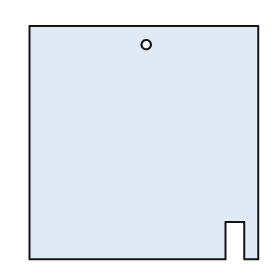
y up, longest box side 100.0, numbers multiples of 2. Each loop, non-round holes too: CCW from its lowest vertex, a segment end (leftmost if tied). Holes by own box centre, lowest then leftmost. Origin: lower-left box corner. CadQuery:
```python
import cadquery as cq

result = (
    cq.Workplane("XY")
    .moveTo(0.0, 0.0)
    .lineTo(84.0, 0.0)
    .lineTo(84.0, 16.0)
    .lineTo(92.0, 16.0)
    .lineTo(92.0, 0.0)
    .lineTo(98.0, 0.0)
    .lineTo(98.0, 100.0)
    .lineTo(0.0, 100.0)
    .close()
    .moveTo(50.0, 92.0)
    .circle(2.0)
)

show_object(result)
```